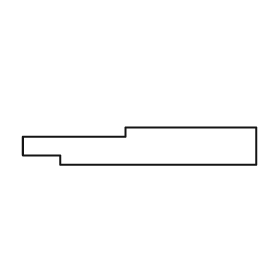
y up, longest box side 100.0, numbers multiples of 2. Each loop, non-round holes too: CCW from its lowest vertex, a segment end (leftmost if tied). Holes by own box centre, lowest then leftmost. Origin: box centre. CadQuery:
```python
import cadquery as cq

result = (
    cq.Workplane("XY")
    .moveTo(-34.0, -8.0)
    .lineTo(50.0, -8.0)
    .lineTo(50.0, 8.0)
    .lineTo(-6.0, 8.0)
    .lineTo(-6.0, 4.0)
    .lineTo(-50.0, 4.0)
    .lineTo(-50.0, -4.0)
    .lineTo(-34.0, -4.0)
    .close()
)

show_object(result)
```